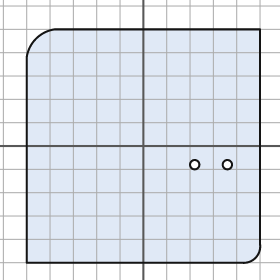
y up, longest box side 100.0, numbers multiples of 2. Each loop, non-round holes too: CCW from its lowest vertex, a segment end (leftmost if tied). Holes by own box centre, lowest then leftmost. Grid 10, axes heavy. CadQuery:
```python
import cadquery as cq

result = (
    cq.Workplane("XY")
    .moveTo(-50.0, -50.0)
    .lineTo(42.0, -50.0)
    .threePointArc((48.0, -48.0), (50.0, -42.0))
    .lineTo(50.0, 50.0)
    .lineTo(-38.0, 50.0)
    .threePointArc((-46.0, 46.0), (-50.0, 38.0))
    .close()
    .moveTo(22.0, -8.0)
    .circle(2.0)
    .moveTo(36.0, -8.0)
    .circle(2.0)
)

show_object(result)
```